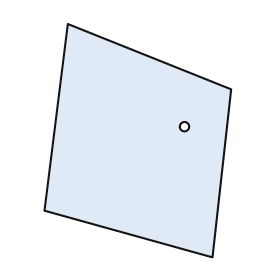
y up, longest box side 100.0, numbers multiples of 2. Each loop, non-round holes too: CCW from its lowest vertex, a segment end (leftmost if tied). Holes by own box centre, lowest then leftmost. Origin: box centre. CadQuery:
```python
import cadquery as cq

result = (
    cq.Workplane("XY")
    .moveTo(32.0, -50.0)
    .lineTo(40.0, 22.0)
    .lineTo(-30.0, 50.0)
    .lineTo(-40.0, -30.0)
    .close()
    .moveTo(20.0, 6.0)
    .circle(2.0)
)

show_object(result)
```